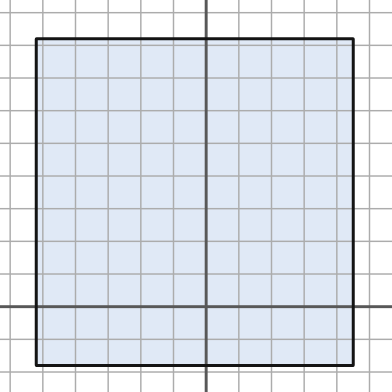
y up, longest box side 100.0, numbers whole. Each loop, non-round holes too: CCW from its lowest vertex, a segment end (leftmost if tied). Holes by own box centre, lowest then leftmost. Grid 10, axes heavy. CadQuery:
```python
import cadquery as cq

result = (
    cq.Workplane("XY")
    .moveTo(-52.0, -18.0)
    .lineTo(45.0, -18.0)
    .lineTo(45.0, 82.0)
    .lineTo(-52.0, 82.0)
    .close()
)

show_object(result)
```